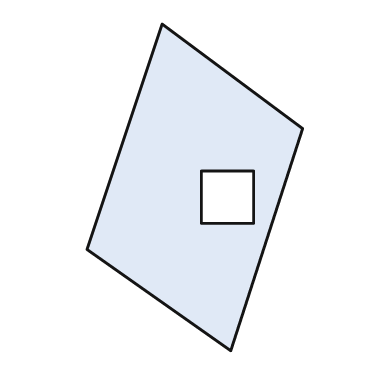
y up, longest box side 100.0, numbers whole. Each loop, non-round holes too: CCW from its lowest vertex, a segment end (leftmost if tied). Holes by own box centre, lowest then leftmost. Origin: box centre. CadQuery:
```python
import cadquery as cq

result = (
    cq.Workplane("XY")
    .moveTo(11.0, -50.0)
    .lineTo(33.0, 18.0)
    .lineTo(-10.0, 50.0)
    .lineTo(-33.0, -19.0)
    .close()
    .moveTo(2.0, -11.0)
    .lineTo(18.0, -11.0)
    .lineTo(18.0, 5.0)
    .lineTo(2.0, 5.0)
    .close()
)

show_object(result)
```